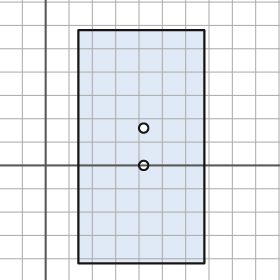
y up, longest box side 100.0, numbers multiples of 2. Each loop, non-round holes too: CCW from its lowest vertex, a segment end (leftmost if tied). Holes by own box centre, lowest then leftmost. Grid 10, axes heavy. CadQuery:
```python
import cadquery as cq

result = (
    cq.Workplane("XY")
    .moveTo(14.0, -42.0)
    .lineTo(68.0, -42.0)
    .lineTo(68.0, 58.0)
    .lineTo(14.0, 58.0)
    .close()
    .moveTo(42.0, 0.0)
    .circle(2.0)
    .moveTo(42.0, 16.0)
    .circle(2.0)
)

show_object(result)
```